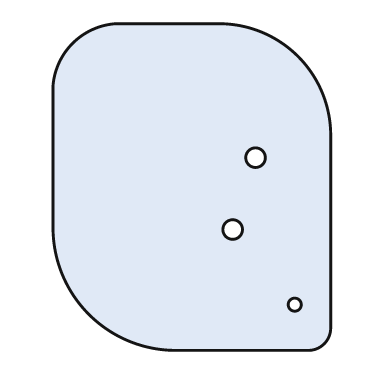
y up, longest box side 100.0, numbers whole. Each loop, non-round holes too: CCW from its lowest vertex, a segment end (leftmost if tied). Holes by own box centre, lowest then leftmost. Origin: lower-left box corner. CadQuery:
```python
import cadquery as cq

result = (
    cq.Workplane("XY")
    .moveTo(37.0, 0.0)
    .lineTo(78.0, 0.0)
    .threePointArc((83.0, 2.0), (85.0, 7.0))
    .lineTo(85.0, 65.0)
    .threePointArc((75.0, 90.0), (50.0, 100.0))
    .lineTo(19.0, 100.0)
    .threePointArc((6.0, 94.0), (0.0, 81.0))
    .lineTo(0.0, 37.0)
    .threePointArc((11.0, 11.0), (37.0, 0.0))
    .close()
    .moveTo(74.0, 14.0)
    .circle(2.0)
    .moveTo(55.0, 37.0)
    .circle(3.0)
    .moveTo(62.0, 59.0)
    .circle(3.0)
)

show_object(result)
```